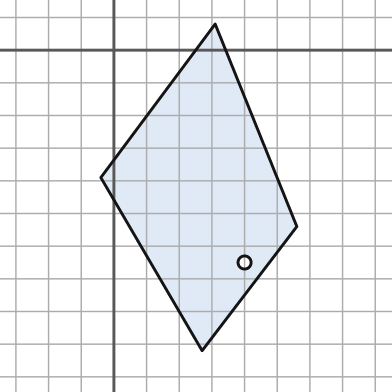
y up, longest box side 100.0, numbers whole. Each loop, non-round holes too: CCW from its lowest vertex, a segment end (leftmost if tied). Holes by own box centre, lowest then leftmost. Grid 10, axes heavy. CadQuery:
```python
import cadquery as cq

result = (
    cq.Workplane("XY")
    .moveTo(27.0, -92.0)
    .lineTo(56.0, -54.0)
    .lineTo(31.0, 8.0)
    .lineTo(-4.0, -39.0)
    .close()
    .moveTo(40.0, -65.0)
    .circle(2.0)
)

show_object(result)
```